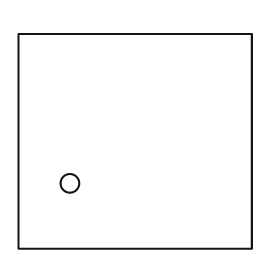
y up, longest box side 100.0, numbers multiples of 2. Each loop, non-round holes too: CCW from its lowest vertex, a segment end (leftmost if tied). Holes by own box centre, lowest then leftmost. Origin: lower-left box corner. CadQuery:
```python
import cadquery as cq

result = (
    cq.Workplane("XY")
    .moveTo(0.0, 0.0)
    .lineTo(100.0, 0.0)
    .lineTo(100.0, 92.0)
    .lineTo(0.0, 92.0)
    .close()
    .moveTo(22.0, 28.0)
    .circle(4.0)
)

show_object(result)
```